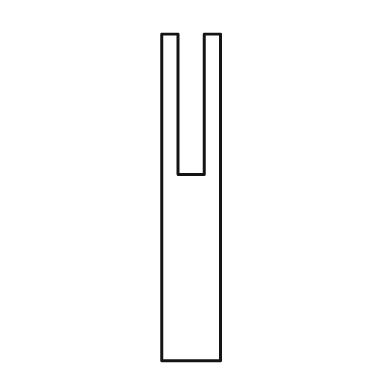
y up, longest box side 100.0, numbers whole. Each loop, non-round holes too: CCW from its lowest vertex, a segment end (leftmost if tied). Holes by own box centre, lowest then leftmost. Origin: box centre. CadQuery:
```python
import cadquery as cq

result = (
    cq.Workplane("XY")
    .moveTo(-9.0, -50.0)
    .lineTo(9.0, -50.0)
    .lineTo(9.0, 50.0)
    .lineTo(4.0, 50.0)
    .lineTo(4.0, 7.0)
    .lineTo(-4.0, 7.0)
    .lineTo(-4.0, 50.0)
    .lineTo(-9.0, 50.0)
    .close()
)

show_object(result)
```